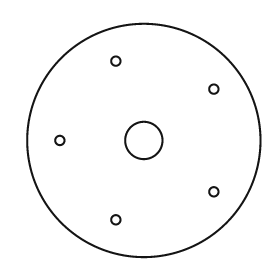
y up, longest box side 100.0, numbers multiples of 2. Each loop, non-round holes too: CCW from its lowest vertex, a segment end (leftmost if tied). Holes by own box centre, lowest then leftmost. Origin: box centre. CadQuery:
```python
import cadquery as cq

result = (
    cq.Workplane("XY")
    .moveTo(0.0, 0.0)
    .circle(50.0)
    .moveTo(-12.0, -34.0)
    .circle(2.0)
    .moveTo(30.0, -22.0)
    .circle(2.0)
    .moveTo(-36.0, 0.0)
    .circle(2.0)
    .moveTo(0.0, 0.0)
    .circle(8.0)
    .moveTo(30.0, 22.0)
    .circle(2.0)
    .moveTo(-12.0, 34.0)
    .circle(2.0)
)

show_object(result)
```